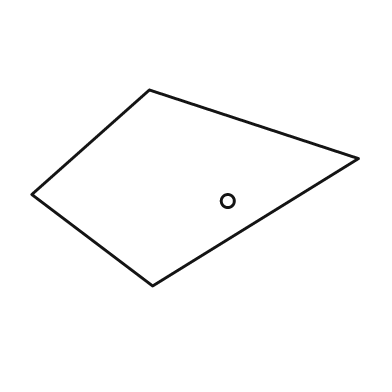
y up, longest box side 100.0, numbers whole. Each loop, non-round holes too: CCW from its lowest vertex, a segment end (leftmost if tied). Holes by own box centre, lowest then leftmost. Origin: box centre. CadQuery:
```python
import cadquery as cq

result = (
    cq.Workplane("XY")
    .moveTo(-13.0, -30.0)
    .lineTo(50.0, 9.0)
    .lineTo(-14.0, 30.0)
    .lineTo(-50.0, -2.0)
    .close()
    .moveTo(10.0, -4.0)
    .circle(2.0)
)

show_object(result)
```